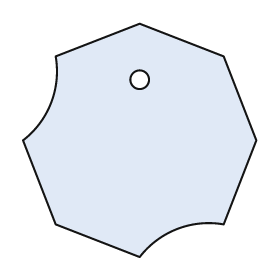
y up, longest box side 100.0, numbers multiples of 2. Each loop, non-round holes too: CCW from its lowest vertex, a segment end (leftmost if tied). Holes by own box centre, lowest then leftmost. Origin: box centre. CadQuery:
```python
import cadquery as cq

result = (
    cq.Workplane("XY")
    .moveTo(0.0, -50.0)
    .threePointArc((16.0, -38.0), (36.0, -36.0))
    .lineTo(50.0, 0.0)
    .lineTo(36.0, 36.0)
    .lineTo(0.0, 50.0)
    .lineTo(-36.0, 36.0)
    .threePointArc((-38.0, 16.0), (-50.0, 0.0))
    .lineTo(-36.0, -36.0)
    .close()
    .moveTo(0.0, 26.0)
    .circle(4.0)
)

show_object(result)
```